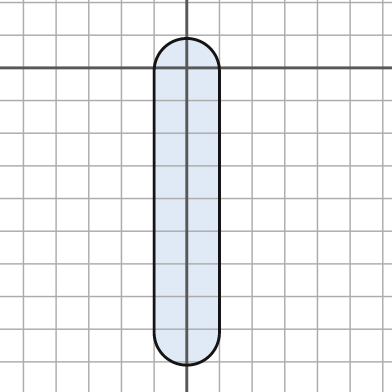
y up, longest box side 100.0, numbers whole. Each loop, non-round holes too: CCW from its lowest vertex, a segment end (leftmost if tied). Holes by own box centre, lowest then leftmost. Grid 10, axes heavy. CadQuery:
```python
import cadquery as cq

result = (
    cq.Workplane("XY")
    .moveTo(-10.0, -81.0)
    .threePointArc((0.0, -91.0), (10.0, -81.0))
    .lineTo(10.0, -1.0)
    .threePointArc((0.0, 9.0), (-10.0, -1.0))
    .close()
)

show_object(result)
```